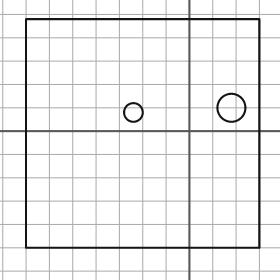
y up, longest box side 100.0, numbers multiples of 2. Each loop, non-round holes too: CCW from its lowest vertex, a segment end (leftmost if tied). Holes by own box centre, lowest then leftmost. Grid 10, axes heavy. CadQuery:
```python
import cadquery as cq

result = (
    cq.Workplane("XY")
    .moveTo(-70.0, -50.0)
    .lineTo(30.0, -50.0)
    .lineTo(30.0, 48.0)
    .lineTo(-70.0, 48.0)
    .close()
    .moveTo(-24.0, 8.0)
    .circle(4.0)
    .moveTo(18.0, 10.0)
    .circle(6.0)
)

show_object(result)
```